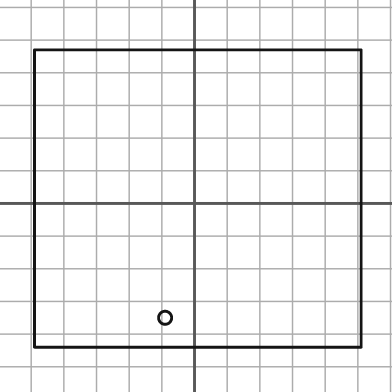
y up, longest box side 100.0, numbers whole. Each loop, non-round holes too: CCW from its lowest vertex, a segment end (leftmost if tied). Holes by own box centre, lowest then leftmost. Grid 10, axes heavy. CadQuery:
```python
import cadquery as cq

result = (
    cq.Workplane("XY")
    .moveTo(-49.0, -44.0)
    .lineTo(51.0, -44.0)
    .lineTo(51.0, 47.0)
    .lineTo(-49.0, 47.0)
    .close()
    .moveTo(-9.0, -35.0)
    .circle(2.0)
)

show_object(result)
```